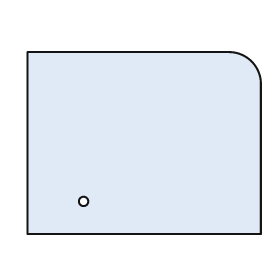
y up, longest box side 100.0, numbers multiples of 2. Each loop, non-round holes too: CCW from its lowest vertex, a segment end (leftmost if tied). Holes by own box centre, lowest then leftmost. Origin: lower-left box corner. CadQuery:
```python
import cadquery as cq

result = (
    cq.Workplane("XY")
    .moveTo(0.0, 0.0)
    .lineTo(100.0, 0.0)
    .lineTo(100.0, 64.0)
    .threePointArc((96.0, 74.0), (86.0, 78.0))
    .lineTo(0.0, 78.0)
    .close()
    .moveTo(24.0, 14.0)
    .circle(2.0)
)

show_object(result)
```